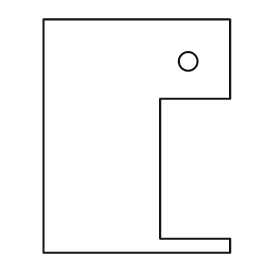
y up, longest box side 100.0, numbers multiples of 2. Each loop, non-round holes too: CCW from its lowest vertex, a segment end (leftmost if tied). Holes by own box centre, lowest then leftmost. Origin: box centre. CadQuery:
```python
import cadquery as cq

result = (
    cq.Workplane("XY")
    .moveTo(-40.0, -50.0)
    .lineTo(40.0, -50.0)
    .lineTo(40.0, -44.0)
    .lineTo(10.0, -44.0)
    .lineTo(10.0, 16.0)
    .lineTo(40.0, 16.0)
    .lineTo(40.0, 50.0)
    .lineTo(-40.0, 50.0)
    .close()
    .moveTo(22.0, 32.0)
    .circle(4.0)
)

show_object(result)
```